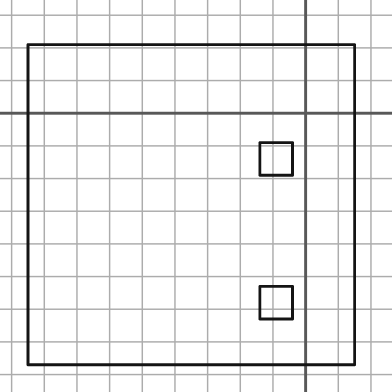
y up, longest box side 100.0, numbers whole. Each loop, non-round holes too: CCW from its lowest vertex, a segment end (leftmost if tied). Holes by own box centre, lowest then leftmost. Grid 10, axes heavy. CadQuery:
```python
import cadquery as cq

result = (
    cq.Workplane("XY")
    .moveTo(-85.0, -77.0)
    .lineTo(15.0, -77.0)
    .lineTo(15.0, 21.0)
    .lineTo(-85.0, 21.0)
    .close()
    .moveTo(-14.0, -63.0)
    .lineTo(-4.0, -63.0)
    .lineTo(-4.0, -53.0)
    .lineTo(-14.0, -53.0)
    .close()
    .moveTo(-14.0, -19.0)
    .lineTo(-4.0, -19.0)
    .lineTo(-4.0, -9.0)
    .lineTo(-14.0, -9.0)
    .close()
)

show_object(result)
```